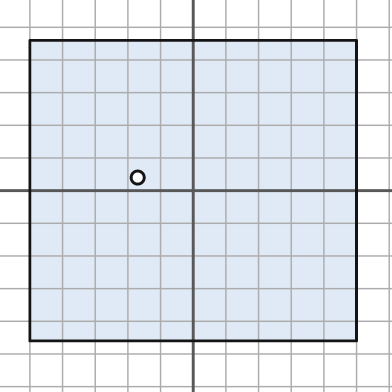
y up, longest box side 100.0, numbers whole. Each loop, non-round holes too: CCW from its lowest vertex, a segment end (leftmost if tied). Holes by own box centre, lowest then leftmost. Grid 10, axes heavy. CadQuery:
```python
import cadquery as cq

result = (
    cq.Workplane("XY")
    .moveTo(-50.0, -46.0)
    .lineTo(50.0, -46.0)
    .lineTo(50.0, 46.0)
    .lineTo(-50.0, 46.0)
    .close()
    .moveTo(-17.0, 4.0)
    .circle(2.0)
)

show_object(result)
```